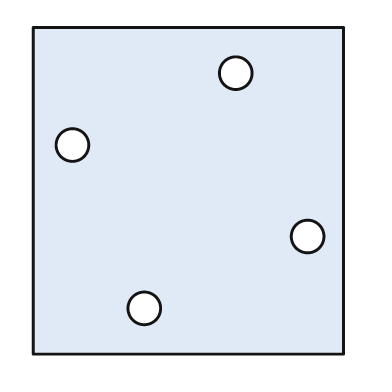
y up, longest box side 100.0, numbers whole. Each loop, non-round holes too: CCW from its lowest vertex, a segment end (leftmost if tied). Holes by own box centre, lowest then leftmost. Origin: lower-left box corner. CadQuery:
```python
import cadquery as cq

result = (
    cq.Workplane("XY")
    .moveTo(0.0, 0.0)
    .lineTo(95.0, 0.0)
    .lineTo(95.0, 100.0)
    .lineTo(0.0, 100.0)
    .close()
    .moveTo(34.0, 14.0)
    .circle(5.0)
    .moveTo(84.0, 36.0)
    .circle(5.0)
    .moveTo(12.0, 64.0)
    .circle(5.0)
    .moveTo(62.0, 86.0)
    .circle(5.0)
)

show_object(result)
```